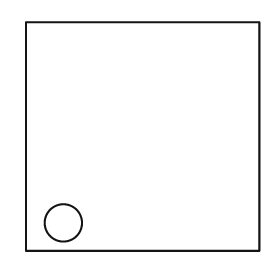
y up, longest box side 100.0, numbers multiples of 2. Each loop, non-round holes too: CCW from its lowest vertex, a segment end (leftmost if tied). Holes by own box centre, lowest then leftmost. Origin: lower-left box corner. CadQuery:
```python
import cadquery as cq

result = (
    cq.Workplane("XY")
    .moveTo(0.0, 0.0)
    .lineTo(100.0, 0.0)
    .lineTo(100.0, 98.0)
    .lineTo(0.0, 98.0)
    .close()
    .moveTo(16.0, 12.0)
    .circle(8.0)
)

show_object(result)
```